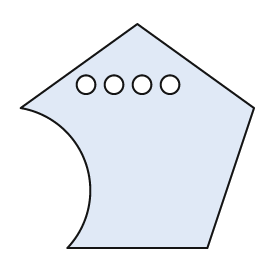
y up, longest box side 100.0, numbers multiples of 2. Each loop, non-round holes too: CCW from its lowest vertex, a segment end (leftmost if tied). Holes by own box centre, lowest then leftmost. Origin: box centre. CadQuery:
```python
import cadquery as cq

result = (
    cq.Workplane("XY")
    .moveTo(-30.0, -48.0)
    .lineTo(30.0, -48.0)
    .lineTo(50.0, 12.0)
    .lineTo(0.0, 48.0)
    .lineTo(-50.0, 12.0)
    .threePointArc((-22.0, -12.0), (-30.0, -48.0))
    .close()
    .moveTo(-22.0, 22.0)
    .circle(4.0)
    .moveTo(-10.0, 22.0)
    .circle(4.0)
    .moveTo(2.0, 22.0)
    .circle(4.0)
    .moveTo(14.0, 22.0)
    .circle(4.0)
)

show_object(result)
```